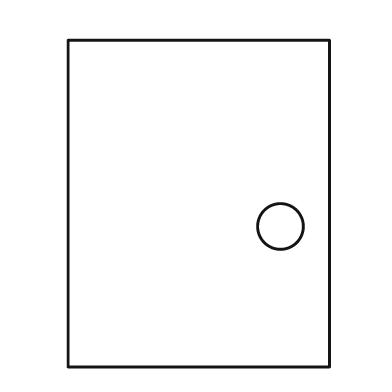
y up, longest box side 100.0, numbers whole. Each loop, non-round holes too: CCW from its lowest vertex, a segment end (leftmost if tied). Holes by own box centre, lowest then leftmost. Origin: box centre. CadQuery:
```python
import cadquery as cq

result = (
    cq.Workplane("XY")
    .moveTo(-40.0, -50.0)
    .lineTo(40.0, -50.0)
    .lineTo(40.0, 50.0)
    .lineTo(-40.0, 50.0)
    .close()
    .moveTo(25.0, -7.0)
    .circle(7.0)
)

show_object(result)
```